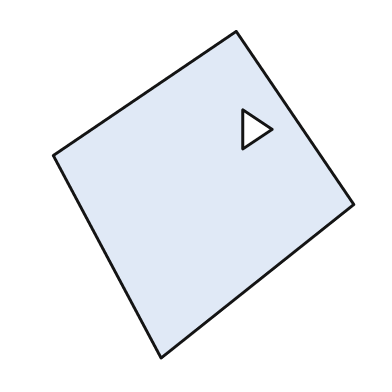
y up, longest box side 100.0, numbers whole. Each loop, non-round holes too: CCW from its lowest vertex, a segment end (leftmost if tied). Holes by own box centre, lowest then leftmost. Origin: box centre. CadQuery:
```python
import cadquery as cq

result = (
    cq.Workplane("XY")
    .moveTo(-13.0, -50.0)
    .lineTo(46.0, -3.0)
    .lineTo(10.0, 50.0)
    .lineTo(-46.0, 12.0)
    .close()
    .moveTo(12.0, 14.0)
    .lineTo(21.0, 20.0)
    .lineTo(12.0, 26.0)
    .close()
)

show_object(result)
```